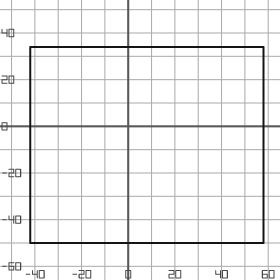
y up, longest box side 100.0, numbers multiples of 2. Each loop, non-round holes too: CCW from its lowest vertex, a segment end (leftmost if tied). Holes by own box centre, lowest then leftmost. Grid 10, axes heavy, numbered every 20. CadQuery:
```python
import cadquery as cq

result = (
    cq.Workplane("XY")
    .moveTo(-42.0, -50.0)
    .lineTo(58.0, -50.0)
    .lineTo(58.0, 34.0)
    .lineTo(-42.0, 34.0)
    .close()
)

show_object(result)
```